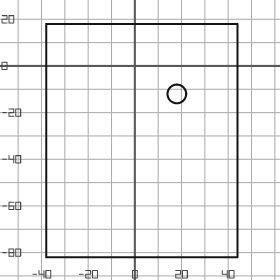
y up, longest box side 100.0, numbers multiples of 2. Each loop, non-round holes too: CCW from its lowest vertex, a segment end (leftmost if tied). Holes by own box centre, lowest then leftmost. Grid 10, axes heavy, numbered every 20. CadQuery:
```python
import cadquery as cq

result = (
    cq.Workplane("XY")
    .moveTo(-38.0, -82.0)
    .lineTo(44.0, -82.0)
    .lineTo(44.0, 18.0)
    .lineTo(-38.0, 18.0)
    .close()
    .moveTo(18.0, -12.0)
    .circle(4.0)
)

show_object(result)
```